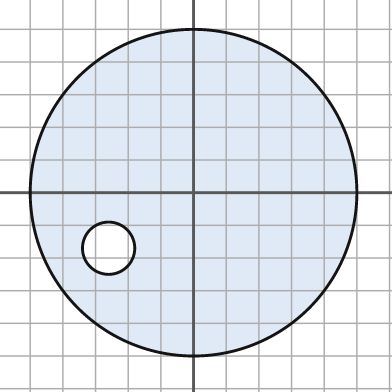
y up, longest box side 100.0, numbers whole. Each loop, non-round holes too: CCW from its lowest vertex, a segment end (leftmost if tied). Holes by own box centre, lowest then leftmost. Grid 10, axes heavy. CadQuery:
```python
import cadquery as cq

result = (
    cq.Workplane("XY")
    .moveTo(0.0, 0.0)
    .circle(50.0)
    .moveTo(-26.0, -17.0)
    .circle(8.0)
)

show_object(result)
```